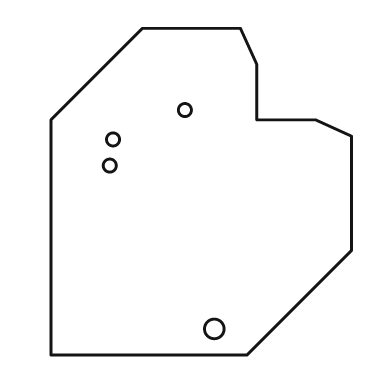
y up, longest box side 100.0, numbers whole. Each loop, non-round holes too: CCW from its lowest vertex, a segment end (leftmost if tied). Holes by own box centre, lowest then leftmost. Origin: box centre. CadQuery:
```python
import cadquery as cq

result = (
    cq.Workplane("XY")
    .moveTo(-46.0, -50.0)
    .lineTo(14.0, -50.0)
    .lineTo(46.0, -18.0)
    .lineTo(46.0, 17.0)
    .lineTo(35.0, 22.0)
    .lineTo(17.0, 22.0)
    .lineTo(17.0, 39.0)
    .lineTo(12.0, 50.0)
    .lineTo(-18.0, 50.0)
    .lineTo(-46.0, 22.0)
    .close()
    .moveTo(4.0, -42.0)
    .circle(3.0)
    .moveTo(-28.0, 8.0)
    .circle(2.0)
    .moveTo(-27.0, 16.0)
    .circle(2.0)
    .moveTo(-5.0, 25.0)
    .circle(2.0)
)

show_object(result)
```